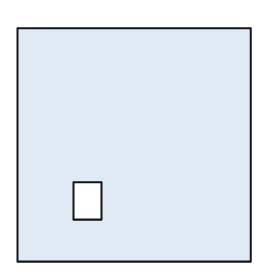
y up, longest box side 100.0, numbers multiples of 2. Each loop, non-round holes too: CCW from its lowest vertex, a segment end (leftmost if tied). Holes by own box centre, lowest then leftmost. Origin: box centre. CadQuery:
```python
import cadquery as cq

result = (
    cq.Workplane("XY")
    .moveTo(-50.0, -50.0)
    .lineTo(50.0, -50.0)
    .lineTo(50.0, 50.0)
    .lineTo(-50.0, 50.0)
    .close()
    .moveTo(-26.0, -32.0)
    .lineTo(-14.0, -32.0)
    .lineTo(-14.0, -16.0)
    .lineTo(-26.0, -16.0)
    .close()
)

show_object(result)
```